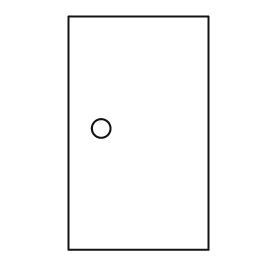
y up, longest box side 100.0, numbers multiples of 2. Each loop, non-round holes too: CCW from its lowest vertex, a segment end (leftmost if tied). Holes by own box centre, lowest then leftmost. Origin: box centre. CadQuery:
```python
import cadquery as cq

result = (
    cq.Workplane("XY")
    .moveTo(-30.0, -50.0)
    .lineTo(30.0, -50.0)
    .lineTo(30.0, 50.0)
    .lineTo(-30.0, 50.0)
    .close()
    .moveTo(-16.0, 2.0)
    .circle(4.0)
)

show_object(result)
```